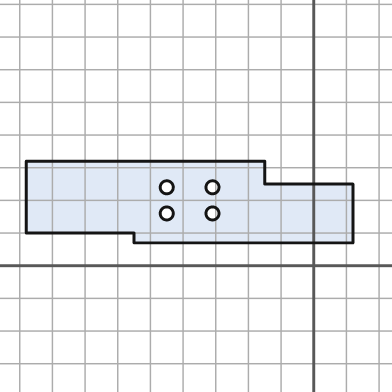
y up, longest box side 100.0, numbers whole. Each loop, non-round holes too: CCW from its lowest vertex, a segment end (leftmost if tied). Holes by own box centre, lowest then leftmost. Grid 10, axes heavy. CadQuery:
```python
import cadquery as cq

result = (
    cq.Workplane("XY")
    .moveTo(-55.0, 7.0)
    .lineTo(12.0, 7.0)
    .lineTo(12.0, 25.0)
    .lineTo(-15.0, 25.0)
    .lineTo(-15.0, 32.0)
    .lineTo(-88.0, 32.0)
    .lineTo(-88.0, 10.0)
    .lineTo(-55.0, 10.0)
    .close()
    .moveTo(-45.0, 16.0)
    .circle(2.0)
    .moveTo(-31.0, 16.0)
    .circle(2.0)
    .moveTo(-45.0, 24.0)
    .circle(2.0)
    .moveTo(-31.0, 24.0)
    .circle(2.0)
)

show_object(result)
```